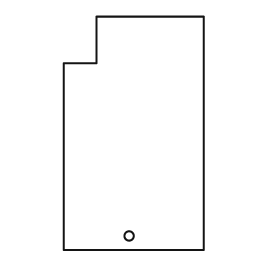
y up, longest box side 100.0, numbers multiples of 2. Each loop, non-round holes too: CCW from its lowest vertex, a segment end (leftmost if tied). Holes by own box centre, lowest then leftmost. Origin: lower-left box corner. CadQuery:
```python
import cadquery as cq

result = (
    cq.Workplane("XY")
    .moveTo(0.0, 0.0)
    .lineTo(60.0, 0.0)
    .lineTo(60.0, 100.0)
    .lineTo(14.0, 100.0)
    .lineTo(14.0, 80.0)
    .lineTo(0.0, 80.0)
    .close()
    .moveTo(28.0, 6.0)
    .circle(2.0)
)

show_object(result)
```